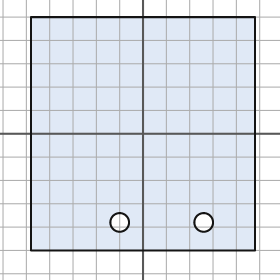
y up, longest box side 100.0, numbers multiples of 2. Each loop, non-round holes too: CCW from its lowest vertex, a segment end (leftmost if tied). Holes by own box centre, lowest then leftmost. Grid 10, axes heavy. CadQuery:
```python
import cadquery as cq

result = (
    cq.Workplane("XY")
    .moveTo(-48.0, -50.0)
    .lineTo(48.0, -50.0)
    .lineTo(48.0, 50.0)
    .lineTo(-48.0, 50.0)
    .close()
    .moveTo(-10.0, -38.0)
    .circle(4.0)
    .moveTo(26.0, -38.0)
    .circle(4.0)
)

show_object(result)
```